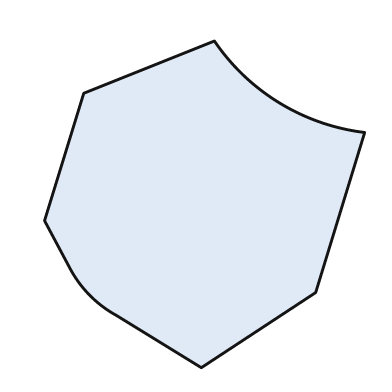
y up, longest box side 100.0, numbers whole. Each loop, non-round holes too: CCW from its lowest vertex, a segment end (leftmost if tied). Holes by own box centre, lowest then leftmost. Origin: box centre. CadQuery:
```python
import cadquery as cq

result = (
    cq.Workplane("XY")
    .moveTo(-1.0, -50.0)
    .lineTo(34.0, -27.0)
    .lineTo(49.0, 22.0)
    .threePointArc((23.0, 31.0), (3.0, 50.0))
    .lineTo(-37.0, 34.0)
    .lineTo(-49.0, -5.0)
    .lineTo(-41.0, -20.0)
    .threePointArc((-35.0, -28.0), (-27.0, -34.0))
    .close()
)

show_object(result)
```